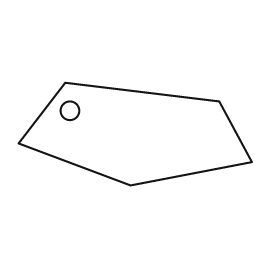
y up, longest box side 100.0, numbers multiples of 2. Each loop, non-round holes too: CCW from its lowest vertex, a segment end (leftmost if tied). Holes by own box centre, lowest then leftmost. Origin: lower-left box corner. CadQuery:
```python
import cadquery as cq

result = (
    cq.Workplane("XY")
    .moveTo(48.0, 0.0)
    .lineTo(100.0, 10.0)
    .lineTo(86.0, 36.0)
    .lineTo(20.0, 44.0)
    .lineTo(0.0, 18.0)
    .close()
    .moveTo(22.0, 32.0)
    .circle(4.0)
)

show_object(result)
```